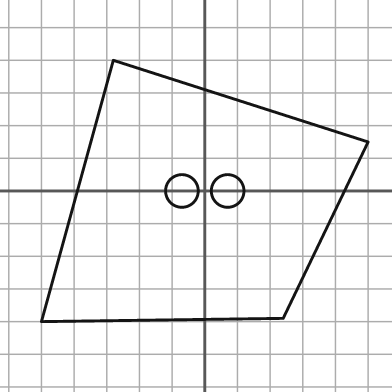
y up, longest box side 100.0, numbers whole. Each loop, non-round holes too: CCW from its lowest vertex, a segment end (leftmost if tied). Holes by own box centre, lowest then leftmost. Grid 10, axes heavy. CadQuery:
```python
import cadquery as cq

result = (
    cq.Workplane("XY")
    .moveTo(-50.0, -40.0)
    .lineTo(24.0, -39.0)
    .lineTo(50.0, 15.0)
    .lineTo(-28.0, 40.0)
    .close()
    .moveTo(-7.0, 0.0)
    .circle(5.0)
    .moveTo(7.0, 0.0)
    .circle(5.0)
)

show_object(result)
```